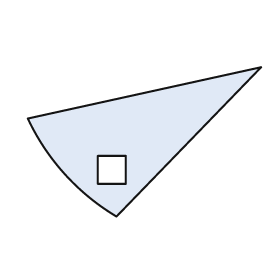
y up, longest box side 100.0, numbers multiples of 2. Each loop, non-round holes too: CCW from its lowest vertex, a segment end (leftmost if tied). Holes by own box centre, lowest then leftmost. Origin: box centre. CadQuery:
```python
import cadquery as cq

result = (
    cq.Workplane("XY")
    .moveTo(-12.0, -32.0)
    .lineTo(50.0, 32.0)
    .lineTo(-50.0, 10.0)
    .threePointArc((-34.0, -14.0), (-12.0, -32.0))
    .close()
    .moveTo(-20.0, -18.0)
    .lineTo(-8.0, -18.0)
    .lineTo(-8.0, -6.0)
    .lineTo(-20.0, -6.0)
    .close()
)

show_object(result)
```